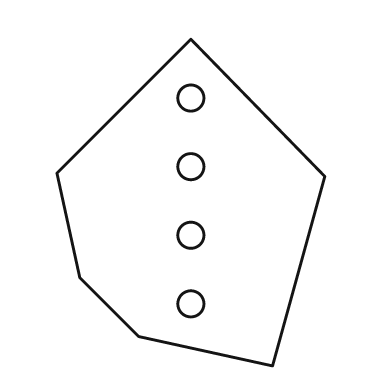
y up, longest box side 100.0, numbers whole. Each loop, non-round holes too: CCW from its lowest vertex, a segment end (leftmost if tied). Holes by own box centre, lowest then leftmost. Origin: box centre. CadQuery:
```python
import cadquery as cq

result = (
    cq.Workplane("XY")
    .moveTo(25.0, -50.0)
    .lineTo(41.0, 8.0)
    .lineTo(0.0, 50.0)
    .lineTo(-41.0, 9.0)
    .lineTo(-34.0, -23.0)
    .lineTo(-16.0, -41.0)
    .close()
    .moveTo(0.0, -31.0)
    .circle(4.0)
    .moveTo(0.0, -10.0)
    .circle(4.0)
    .moveTo(0.0, 11.0)
    .circle(4.0)
    .moveTo(0.0, 32.0)
    .circle(4.0)
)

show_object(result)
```